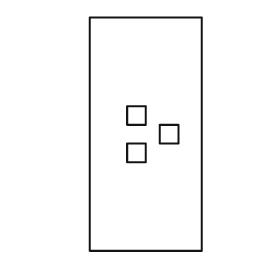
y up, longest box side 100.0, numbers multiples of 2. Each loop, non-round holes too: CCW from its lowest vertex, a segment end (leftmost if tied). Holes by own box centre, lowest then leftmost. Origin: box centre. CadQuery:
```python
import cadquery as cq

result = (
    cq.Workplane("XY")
    .moveTo(-24.0, -50.0)
    .lineTo(24.0, -50.0)
    .lineTo(24.0, 50.0)
    .lineTo(-24.0, 50.0)
    .close()
    .moveTo(-8.0, -12.0)
    .lineTo(0.0, -12.0)
    .lineTo(0.0, -4.0)
    .lineTo(-8.0, -4.0)
    .close()
    .moveTo(6.0, -4.0)
    .lineTo(14.0, -4.0)
    .lineTo(14.0, 4.0)
    .lineTo(6.0, 4.0)
    .close()
    .moveTo(-8.0, 4.0)
    .lineTo(0.0, 4.0)
    .lineTo(0.0, 12.0)
    .lineTo(-8.0, 12.0)
    .close()
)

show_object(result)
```